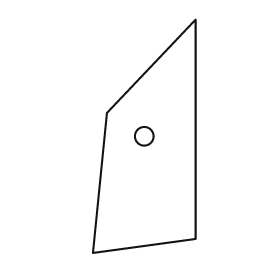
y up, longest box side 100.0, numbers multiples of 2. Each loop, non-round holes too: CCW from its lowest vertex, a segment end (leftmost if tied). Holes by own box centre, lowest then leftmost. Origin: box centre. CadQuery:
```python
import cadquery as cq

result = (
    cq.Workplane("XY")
    .moveTo(-22.0, -50.0)
    .lineTo(22.0, -44.0)
    .lineTo(22.0, 50.0)
    .lineTo(-16.0, 10.0)
    .close()
    .moveTo(0.0, 0.0)
    .circle(4.0)
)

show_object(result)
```